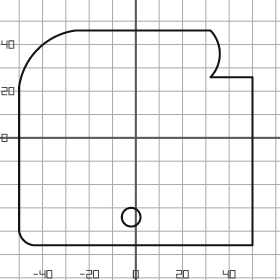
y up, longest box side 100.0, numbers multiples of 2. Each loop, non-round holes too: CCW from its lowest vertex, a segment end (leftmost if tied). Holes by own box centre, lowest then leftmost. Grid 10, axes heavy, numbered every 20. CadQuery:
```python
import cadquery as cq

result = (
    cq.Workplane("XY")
    .moveTo(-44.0, -46.0)
    .lineTo(50.0, -46.0)
    .lineTo(50.0, 26.0)
    .lineTo(32.0, 26.0)
    .threePointArc((36.0, 36.0), (32.0, 46.0))
    .lineTo(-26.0, 46.0)
    .threePointArc((-42.0, 38.0), (-50.0, 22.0))
    .lineTo(-50.0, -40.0)
    .threePointArc((-48.0, -44.0), (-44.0, -46.0))
    .close()
    .moveTo(-2.0, -34.0)
    .circle(4.0)
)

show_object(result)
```